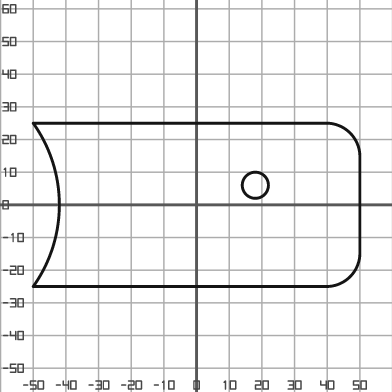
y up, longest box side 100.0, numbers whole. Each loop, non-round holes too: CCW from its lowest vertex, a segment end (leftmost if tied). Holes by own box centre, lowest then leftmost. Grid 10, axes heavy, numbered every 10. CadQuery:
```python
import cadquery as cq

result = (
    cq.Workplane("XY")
    .moveTo(-50.0, -25.0)
    .lineTo(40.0, -25.0)
    .threePointArc((47.0, -22.0), (50.0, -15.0))
    .lineTo(50.0, 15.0)
    .threePointArc((47.0, 22.0), (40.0, 25.0))
    .lineTo(-50.0, 25.0)
    .threePointArc((-42.0, 0.0), (-50.0, -25.0))
    .close()
    .moveTo(18.0, 6.0)
    .circle(4.0)
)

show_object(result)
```